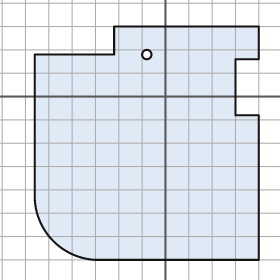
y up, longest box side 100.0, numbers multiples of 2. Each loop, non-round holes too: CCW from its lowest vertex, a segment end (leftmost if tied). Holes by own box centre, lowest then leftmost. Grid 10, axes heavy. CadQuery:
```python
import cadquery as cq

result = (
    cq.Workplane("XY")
    .moveTo(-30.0, -70.0)
    .lineTo(40.0, -70.0)
    .lineTo(40.0, -8.0)
    .lineTo(30.0, -8.0)
    .lineTo(30.0, 16.0)
    .lineTo(40.0, 16.0)
    .lineTo(40.0, 30.0)
    .lineTo(-22.0, 30.0)
    .lineTo(-22.0, 18.0)
    .lineTo(-56.0, 18.0)
    .lineTo(-56.0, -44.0)
    .threePointArc((-48.0, -62.0), (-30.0, -70.0))
    .close()
    .moveTo(-8.0, 18.0)
    .circle(2.0)
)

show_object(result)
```